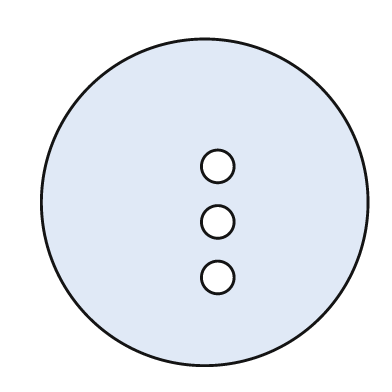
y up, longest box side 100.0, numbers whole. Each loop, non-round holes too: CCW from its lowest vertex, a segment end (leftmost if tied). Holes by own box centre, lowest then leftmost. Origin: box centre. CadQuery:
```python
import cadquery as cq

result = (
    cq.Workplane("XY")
    .moveTo(0.0, 0.0)
    .circle(50.0)
    .moveTo(4.0, -23.0)
    .circle(5.0)
    .moveTo(4.0, -6.0)
    .circle(5.0)
    .moveTo(4.0, 11.0)
    .circle(5.0)
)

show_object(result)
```